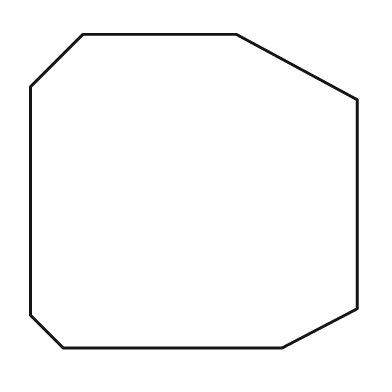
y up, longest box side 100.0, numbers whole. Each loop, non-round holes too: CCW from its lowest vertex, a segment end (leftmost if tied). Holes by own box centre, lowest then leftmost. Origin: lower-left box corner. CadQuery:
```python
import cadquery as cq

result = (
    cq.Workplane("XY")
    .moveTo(10.0, 0.0)
    .lineTo(77.0, 0.0)
    .lineTo(100.0, 12.0)
    .lineTo(100.0, 76.0)
    .lineTo(63.0, 96.0)
    .lineTo(16.0, 96.0)
    .lineTo(0.0, 80.0)
    .lineTo(0.0, 10.0)
    .close()
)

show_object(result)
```